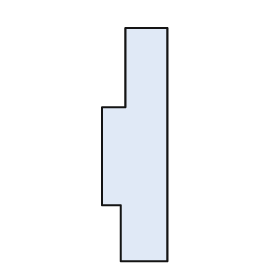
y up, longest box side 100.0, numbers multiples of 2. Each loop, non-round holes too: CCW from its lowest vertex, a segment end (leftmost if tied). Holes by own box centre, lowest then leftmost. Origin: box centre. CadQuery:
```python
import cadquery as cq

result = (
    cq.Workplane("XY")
    .moveTo(-6.0, -50.0)
    .lineTo(14.0, -50.0)
    .lineTo(14.0, 50.0)
    .lineTo(-4.0, 50.0)
    .lineTo(-4.0, 16.0)
    .lineTo(-14.0, 16.0)
    .lineTo(-14.0, -26.0)
    .lineTo(-6.0, -26.0)
    .close()
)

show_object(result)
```